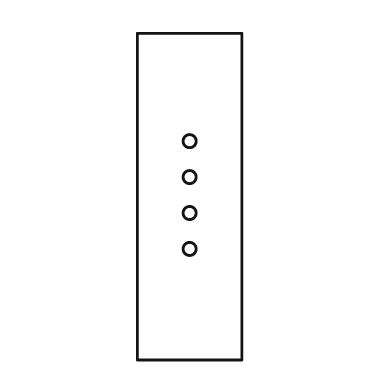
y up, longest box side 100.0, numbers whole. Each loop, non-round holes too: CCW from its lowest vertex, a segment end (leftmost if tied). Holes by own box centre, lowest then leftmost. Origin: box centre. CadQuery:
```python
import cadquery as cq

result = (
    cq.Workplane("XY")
    .moveTo(-16.0, -50.0)
    .lineTo(16.0, -50.0)
    .lineTo(16.0, 50.0)
    .lineTo(-16.0, 50.0)
    .close()
    .moveTo(0.0, -16.0)
    .circle(2.0)
    .moveTo(0.0, -5.0)
    .circle(2.0)
    .moveTo(0.0, 6.0)
    .circle(2.0)
    .moveTo(0.0, 17.0)
    .circle(2.0)
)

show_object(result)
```